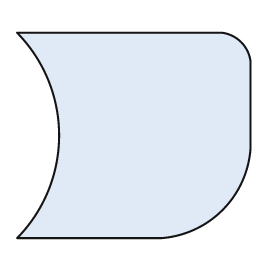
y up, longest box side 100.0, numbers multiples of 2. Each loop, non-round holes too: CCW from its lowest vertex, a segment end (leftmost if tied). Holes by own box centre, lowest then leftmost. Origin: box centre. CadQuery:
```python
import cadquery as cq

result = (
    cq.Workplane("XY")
    .moveTo(-50.0, -44.0)
    .lineTo(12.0, -44.0)
    .threePointArc((38.0, -32.0), (50.0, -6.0))
    .lineTo(50.0, 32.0)
    .threePointArc((46.0, 40.0), (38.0, 44.0))
    .lineTo(-50.0, 44.0)
    .threePointArc((-32.0, 0.0), (-50.0, -44.0))
    .close()
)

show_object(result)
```